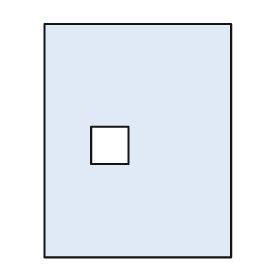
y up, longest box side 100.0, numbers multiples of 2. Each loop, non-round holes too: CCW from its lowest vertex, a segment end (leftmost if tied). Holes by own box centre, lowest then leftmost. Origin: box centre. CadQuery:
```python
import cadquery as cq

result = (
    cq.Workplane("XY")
    .moveTo(-40.0, -50.0)
    .lineTo(40.0, -50.0)
    .lineTo(40.0, 50.0)
    .lineTo(-40.0, 50.0)
    .close()
    .moveTo(-20.0, -10.0)
    .lineTo(-4.0, -10.0)
    .lineTo(-4.0, 6.0)
    .lineTo(-20.0, 6.0)
    .close()
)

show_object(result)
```